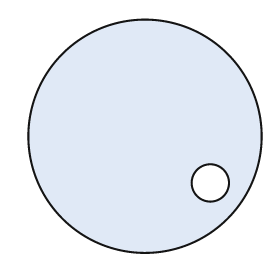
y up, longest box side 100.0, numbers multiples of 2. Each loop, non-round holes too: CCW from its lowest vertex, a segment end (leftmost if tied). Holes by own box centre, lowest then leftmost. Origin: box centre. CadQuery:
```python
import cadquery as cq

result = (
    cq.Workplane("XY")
    .moveTo(0.0, 0.0)
    .circle(50.0)
    .moveTo(28.0, -20.0)
    .circle(8.0)
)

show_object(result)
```